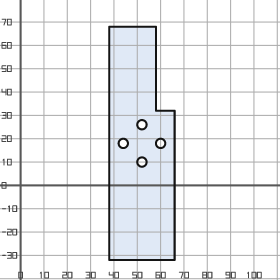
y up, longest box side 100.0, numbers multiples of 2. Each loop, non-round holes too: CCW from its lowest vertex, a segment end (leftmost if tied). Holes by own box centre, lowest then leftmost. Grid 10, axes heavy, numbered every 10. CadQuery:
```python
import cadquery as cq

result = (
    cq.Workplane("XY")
    .moveTo(38.0, -32.0)
    .lineTo(66.0, -32.0)
    .lineTo(66.0, 32.0)
    .lineTo(58.0, 32.0)
    .lineTo(58.0, 68.0)
    .lineTo(38.0, 68.0)
    .close()
    .moveTo(52.0, 10.0)
    .circle(2.0)
    .moveTo(44.0, 18.0)
    .circle(2.0)
    .moveTo(60.0, 18.0)
    .circle(2.0)
    .moveTo(52.0, 26.0)
    .circle(2.0)
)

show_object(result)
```